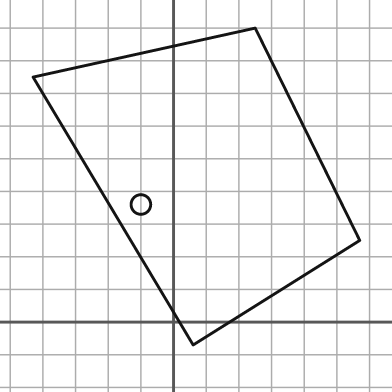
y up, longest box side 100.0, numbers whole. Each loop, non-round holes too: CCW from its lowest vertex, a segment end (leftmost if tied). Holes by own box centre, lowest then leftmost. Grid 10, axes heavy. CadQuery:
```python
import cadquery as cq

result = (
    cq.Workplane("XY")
    .moveTo(6.0, -7.0)
    .lineTo(57.0, 25.0)
    .lineTo(25.0, 90.0)
    .lineTo(-43.0, 75.0)
    .close()
    .moveTo(-10.0, 36.0)
    .circle(3.0)
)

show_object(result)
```